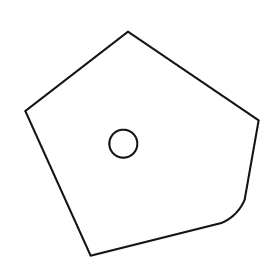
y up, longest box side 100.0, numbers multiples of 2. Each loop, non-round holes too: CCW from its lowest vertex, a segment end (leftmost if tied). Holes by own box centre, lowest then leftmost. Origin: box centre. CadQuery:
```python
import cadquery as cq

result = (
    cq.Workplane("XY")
    .moveTo(-22.0, -48.0)
    .lineTo(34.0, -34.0)
    .threePointArc((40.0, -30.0), (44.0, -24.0))
    .lineTo(50.0, 10.0)
    .lineTo(-6.0, 48.0)
    .lineTo(-50.0, 14.0)
    .close()
    .moveTo(-8.0, 0.0)
    .circle(6.0)
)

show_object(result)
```